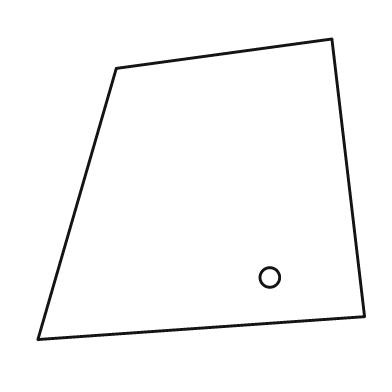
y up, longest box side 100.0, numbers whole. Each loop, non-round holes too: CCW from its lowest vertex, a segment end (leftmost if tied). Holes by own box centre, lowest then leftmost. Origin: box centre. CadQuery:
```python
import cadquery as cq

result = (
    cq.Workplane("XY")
    .moveTo(-50.0, -46.0)
    .lineTo(50.0, -39.0)
    .lineTo(40.0, 46.0)
    .lineTo(-26.0, 37.0)
    .close()
    .moveTo(21.0, -27.0)
    .circle(3.0)
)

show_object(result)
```